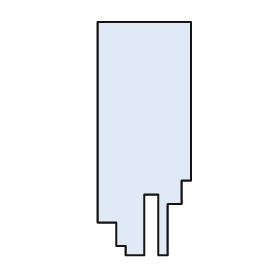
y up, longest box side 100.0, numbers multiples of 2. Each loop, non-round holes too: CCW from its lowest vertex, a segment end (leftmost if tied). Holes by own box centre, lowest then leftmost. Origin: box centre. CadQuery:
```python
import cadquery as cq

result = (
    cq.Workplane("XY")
    .moveTo(-8.0, -50.0)
    .lineTo(0.0, -50.0)
    .lineTo(0.0, -24.0)
    .lineTo(6.0, -24.0)
    .lineTo(6.0, -50.0)
    .lineTo(10.0, -50.0)
    .lineTo(10.0, -28.0)
    .lineTo(16.0, -28.0)
    .lineTo(16.0, -18.0)
    .lineTo(20.0, -18.0)
    .lineTo(20.0, 50.0)
    .lineTo(-20.0, 50.0)
    .lineTo(-20.0, -36.0)
    .lineTo(-12.0, -36.0)
    .lineTo(-12.0, -46.0)
    .lineTo(-8.0, -46.0)
    .close()
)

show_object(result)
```